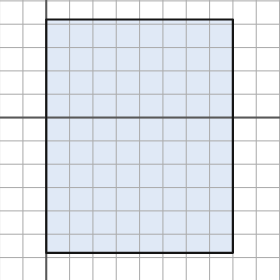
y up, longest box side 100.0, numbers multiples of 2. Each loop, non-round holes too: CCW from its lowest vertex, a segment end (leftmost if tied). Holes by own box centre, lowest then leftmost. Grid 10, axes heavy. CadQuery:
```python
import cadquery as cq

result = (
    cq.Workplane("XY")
    .moveTo(0.0, -58.0)
    .lineTo(80.0, -58.0)
    .lineTo(80.0, 42.0)
    .lineTo(0.0, 42.0)
    .close()
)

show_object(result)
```